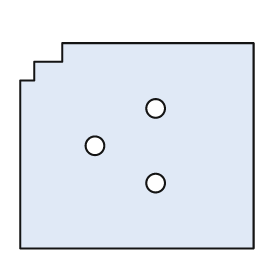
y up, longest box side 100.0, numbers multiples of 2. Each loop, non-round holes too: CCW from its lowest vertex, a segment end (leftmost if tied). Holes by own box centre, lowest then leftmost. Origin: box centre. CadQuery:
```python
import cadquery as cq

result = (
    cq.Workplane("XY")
    .moveTo(-50.0, -44.0)
    .lineTo(50.0, -44.0)
    .lineTo(50.0, 44.0)
    .lineTo(-32.0, 44.0)
    .lineTo(-32.0, 36.0)
    .lineTo(-44.0, 36.0)
    .lineTo(-44.0, 28.0)
    .lineTo(-50.0, 28.0)
    .close()
    .moveTo(8.0, -16.0)
    .circle(4.0)
    .moveTo(-18.0, 0.0)
    .circle(4.0)
    .moveTo(8.0, 16.0)
    .circle(4.0)
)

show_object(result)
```